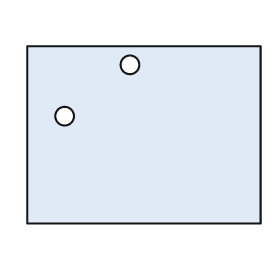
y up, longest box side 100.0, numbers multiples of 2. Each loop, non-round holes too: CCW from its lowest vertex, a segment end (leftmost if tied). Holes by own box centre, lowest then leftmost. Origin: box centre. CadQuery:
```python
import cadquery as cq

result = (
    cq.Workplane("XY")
    .moveTo(-50.0, -38.0)
    .lineTo(50.0, -38.0)
    .lineTo(50.0, 38.0)
    .lineTo(-50.0, 38.0)
    .close()
    .moveTo(-34.0, 8.0)
    .circle(4.0)
    .moveTo(-6.0, 30.0)
    .circle(4.0)
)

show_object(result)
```